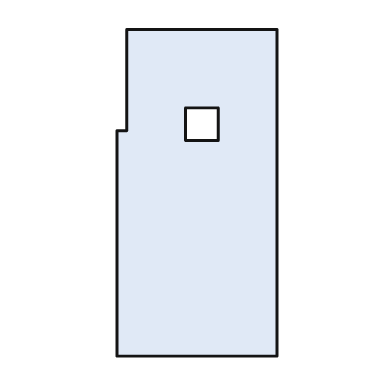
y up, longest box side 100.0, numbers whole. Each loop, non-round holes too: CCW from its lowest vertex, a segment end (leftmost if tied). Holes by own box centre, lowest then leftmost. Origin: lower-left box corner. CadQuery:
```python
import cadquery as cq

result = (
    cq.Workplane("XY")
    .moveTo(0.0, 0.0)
    .lineTo(49.0, 0.0)
    .lineTo(49.0, 100.0)
    .lineTo(3.0, 100.0)
    .lineTo(3.0, 69.0)
    .lineTo(0.0, 69.0)
    .close()
    .moveTo(21.0, 66.0)
    .lineTo(31.0, 66.0)
    .lineTo(31.0, 76.0)
    .lineTo(21.0, 76.0)
    .close()
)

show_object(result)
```